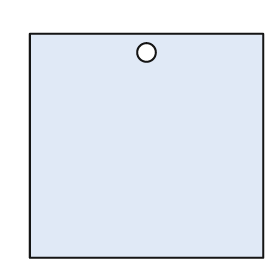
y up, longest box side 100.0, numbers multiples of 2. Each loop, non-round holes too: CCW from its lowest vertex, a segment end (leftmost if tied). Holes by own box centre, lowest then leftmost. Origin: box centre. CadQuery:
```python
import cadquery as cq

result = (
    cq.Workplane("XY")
    .moveTo(-50.0, -48.0)
    .lineTo(50.0, -48.0)
    .lineTo(50.0, 48.0)
    .lineTo(-50.0, 48.0)
    .close()
    .moveTo(0.0, 40.0)
    .circle(4.0)
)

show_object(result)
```